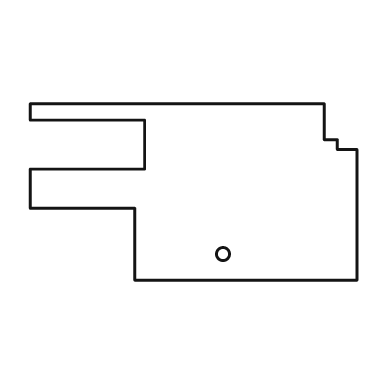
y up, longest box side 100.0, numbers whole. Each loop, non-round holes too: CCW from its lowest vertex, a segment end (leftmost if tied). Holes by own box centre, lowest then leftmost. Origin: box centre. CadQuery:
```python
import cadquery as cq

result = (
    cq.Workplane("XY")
    .moveTo(-18.0, -27.0)
    .lineTo(50.0, -27.0)
    .lineTo(50.0, 13.0)
    .lineTo(44.0, 13.0)
    .lineTo(44.0, 16.0)
    .lineTo(40.0, 16.0)
    .lineTo(40.0, 27.0)
    .lineTo(-50.0, 27.0)
    .lineTo(-50.0, 22.0)
    .lineTo(-15.0, 22.0)
    .lineTo(-15.0, 7.0)
    .lineTo(-50.0, 7.0)
    .lineTo(-50.0, -5.0)
    .lineTo(-18.0, -5.0)
    .close()
    .moveTo(9.0, -19.0)
    .circle(2.0)
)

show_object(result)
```